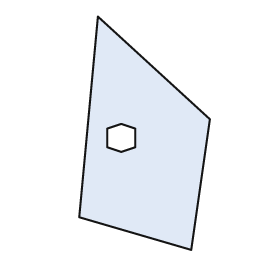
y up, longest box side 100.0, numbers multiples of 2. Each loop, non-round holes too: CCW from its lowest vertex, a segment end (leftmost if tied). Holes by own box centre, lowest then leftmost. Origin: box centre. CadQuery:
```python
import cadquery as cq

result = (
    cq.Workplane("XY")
    .moveTo(20.0, -50.0)
    .lineTo(28.0, 6.0)
    .lineTo(-20.0, 50.0)
    .lineTo(-28.0, -36.0)
    .close()
    .moveTo(-10.0, -8.0)
    .lineTo(-4.0, -6.0)
    .lineTo(-4.0, 2.0)
    .lineTo(-10.0, 4.0)
    .lineTo(-16.0, 2.0)
    .lineTo(-16.0, -6.0)
    .close()
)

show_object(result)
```